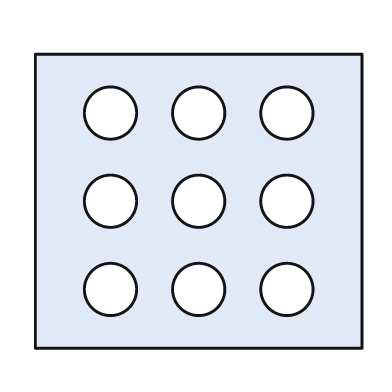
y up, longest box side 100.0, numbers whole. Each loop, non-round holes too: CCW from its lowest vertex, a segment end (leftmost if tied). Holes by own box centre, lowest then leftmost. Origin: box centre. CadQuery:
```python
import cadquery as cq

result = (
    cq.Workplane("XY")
    .moveTo(-50.0, -45.0)
    .lineTo(50.0, -45.0)
    .lineTo(50.0, 45.0)
    .lineTo(-50.0, 45.0)
    .close()
    .moveTo(-27.0, -27.0)
    .circle(8.0)
    .moveTo(0.0, -27.0)
    .circle(8.0)
    .moveTo(27.0, -27.0)
    .circle(8.0)
    .moveTo(-27.0, 0.0)
    .circle(8.0)
    .moveTo(0.0, 0.0)
    .circle(8.0)
    .moveTo(27.0, 0.0)
    .circle(8.0)
    .moveTo(-27.0, 27.0)
    .circle(8.0)
    .moveTo(0.0, 27.0)
    .circle(8.0)
    .moveTo(27.0, 27.0)
    .circle(8.0)
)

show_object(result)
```